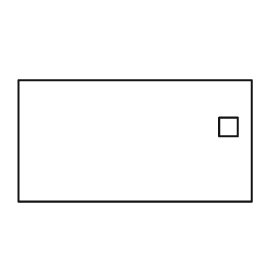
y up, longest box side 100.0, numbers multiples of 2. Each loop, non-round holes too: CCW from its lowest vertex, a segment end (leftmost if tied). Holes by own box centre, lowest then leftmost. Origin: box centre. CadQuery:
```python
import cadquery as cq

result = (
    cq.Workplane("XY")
    .moveTo(-50.0, -26.0)
    .lineTo(50.0, -26.0)
    .lineTo(50.0, 26.0)
    .lineTo(-50.0, 26.0)
    .close()
    .moveTo(36.0, 2.0)
    .lineTo(44.0, 2.0)
    .lineTo(44.0, 10.0)
    .lineTo(36.0, 10.0)
    .close()
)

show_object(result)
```